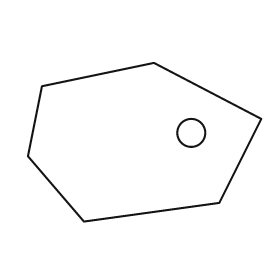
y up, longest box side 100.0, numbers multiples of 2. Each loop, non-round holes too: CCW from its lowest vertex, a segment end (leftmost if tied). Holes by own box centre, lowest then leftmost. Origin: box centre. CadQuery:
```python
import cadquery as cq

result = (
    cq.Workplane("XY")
    .moveTo(-26.0, -34.0)
    .lineTo(32.0, -26.0)
    .lineTo(50.0, 10.0)
    .lineTo(4.0, 34.0)
    .lineTo(-44.0, 24.0)
    .lineTo(-50.0, -6.0)
    .close()
    .moveTo(20.0, 4.0)
    .circle(6.0)
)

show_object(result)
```